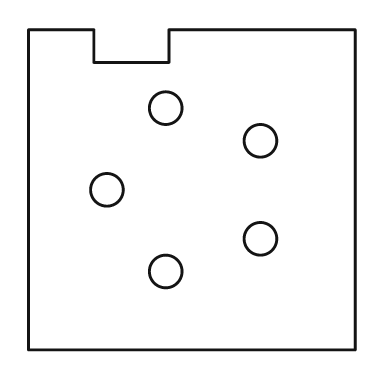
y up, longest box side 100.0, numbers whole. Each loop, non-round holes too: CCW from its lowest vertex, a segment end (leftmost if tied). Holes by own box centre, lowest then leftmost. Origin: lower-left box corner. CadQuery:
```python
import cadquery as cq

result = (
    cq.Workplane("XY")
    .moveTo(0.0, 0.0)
    .lineTo(100.0, 0.0)
    .lineTo(100.0, 98.0)
    .lineTo(43.0, 98.0)
    .lineTo(43.0, 88.0)
    .lineTo(20.0, 88.0)
    .lineTo(20.0, 98.0)
    .lineTo(0.0, 98.0)
    .close()
    .moveTo(42.0, 24.0)
    .circle(5.0)
    .moveTo(71.0, 34.0)
    .circle(5.0)
    .moveTo(24.0, 49.0)
    .circle(5.0)
    .moveTo(71.0, 64.0)
    .circle(5.0)
    .moveTo(42.0, 74.0)
    .circle(5.0)
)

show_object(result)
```